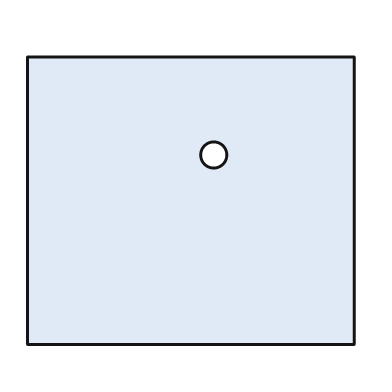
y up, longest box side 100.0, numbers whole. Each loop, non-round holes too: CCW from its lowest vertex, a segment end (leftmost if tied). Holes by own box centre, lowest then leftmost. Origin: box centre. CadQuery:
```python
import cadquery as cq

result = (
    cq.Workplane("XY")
    .moveTo(-50.0, -44.0)
    .lineTo(50.0, -44.0)
    .lineTo(50.0, 44.0)
    .lineTo(-50.0, 44.0)
    .close()
    .moveTo(7.0, 14.0)
    .circle(4.0)
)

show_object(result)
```